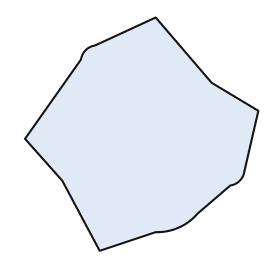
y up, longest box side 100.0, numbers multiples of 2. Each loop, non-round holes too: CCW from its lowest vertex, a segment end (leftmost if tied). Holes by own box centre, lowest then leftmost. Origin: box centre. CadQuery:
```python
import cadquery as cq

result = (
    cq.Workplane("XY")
    .moveTo(-18.0, -50.0)
    .lineTo(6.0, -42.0)
    .threePointArc((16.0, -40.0), (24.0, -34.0))
    .lineTo(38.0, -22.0)
    .threePointArc((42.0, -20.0), (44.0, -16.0))
    .lineTo(50.0, 10.0)
    .lineTo(30.0, 22.0)
    .lineTo(6.0, 50.0)
    .lineTo(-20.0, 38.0)
    .threePointArc((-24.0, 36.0), (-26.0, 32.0))
    .lineTo(-50.0, -2.0)
    .lineTo(-34.0, -20.0)
    .close()
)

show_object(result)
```